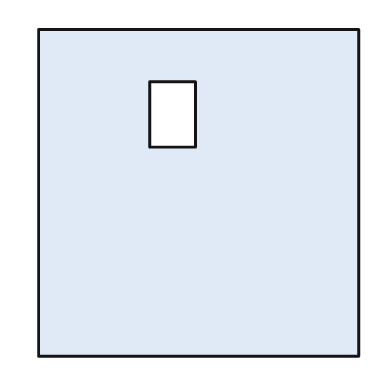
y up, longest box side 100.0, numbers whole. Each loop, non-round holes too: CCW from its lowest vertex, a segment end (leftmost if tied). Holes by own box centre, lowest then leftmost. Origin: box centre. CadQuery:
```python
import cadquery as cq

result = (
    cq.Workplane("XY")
    .moveTo(-49.0, -50.0)
    .lineTo(49.0, -50.0)
    .lineTo(49.0, 50.0)
    .lineTo(-49.0, 50.0)
    .close()
    .moveTo(-15.0, 14.0)
    .lineTo(-1.0, 14.0)
    .lineTo(-1.0, 34.0)
    .lineTo(-15.0, 34.0)
    .close()
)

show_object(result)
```